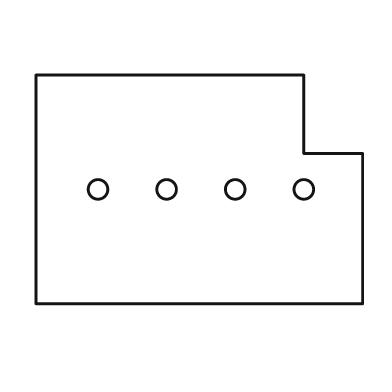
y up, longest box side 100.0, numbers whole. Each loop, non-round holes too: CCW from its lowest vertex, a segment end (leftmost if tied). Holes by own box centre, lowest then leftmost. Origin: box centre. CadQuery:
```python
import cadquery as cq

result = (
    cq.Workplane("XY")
    .moveTo(-50.0, -35.0)
    .lineTo(50.0, -35.0)
    .lineTo(50.0, 11.0)
    .lineTo(32.0, 11.0)
    .lineTo(32.0, 35.0)
    .lineTo(-50.0, 35.0)
    .close()
    .moveTo(-31.0, 0.0)
    .circle(3.0)
    .moveTo(-10.0, 0.0)
    .circle(3.0)
    .moveTo(11.0, 0.0)
    .circle(3.0)
    .moveTo(32.0, 0.0)
    .circle(3.0)
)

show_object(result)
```